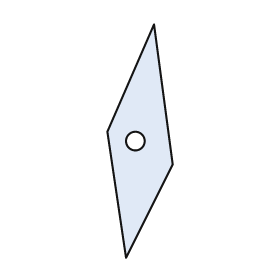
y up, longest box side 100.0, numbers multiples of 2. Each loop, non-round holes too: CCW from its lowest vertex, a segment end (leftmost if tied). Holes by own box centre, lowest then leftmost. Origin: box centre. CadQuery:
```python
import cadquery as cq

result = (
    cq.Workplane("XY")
    .moveTo(-6.0, -50.0)
    .lineTo(14.0, -10.0)
    .lineTo(6.0, 50.0)
    .lineTo(-14.0, 4.0)
    .close()
    .moveTo(-2.0, 0.0)
    .circle(4.0)
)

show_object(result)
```